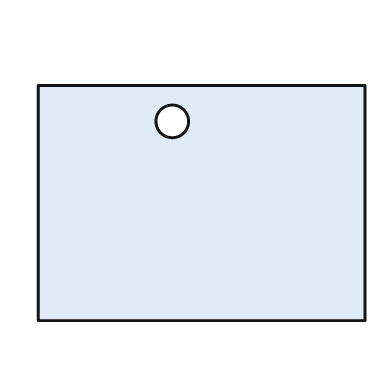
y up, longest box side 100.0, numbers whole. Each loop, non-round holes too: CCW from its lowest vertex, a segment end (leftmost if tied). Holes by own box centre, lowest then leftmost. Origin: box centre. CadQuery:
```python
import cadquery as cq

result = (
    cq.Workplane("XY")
    .moveTo(-50.0, -36.0)
    .lineTo(50.0, -36.0)
    .lineTo(50.0, 36.0)
    .lineTo(-50.0, 36.0)
    .close()
    .moveTo(-9.0, 25.0)
    .circle(5.0)
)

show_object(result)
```